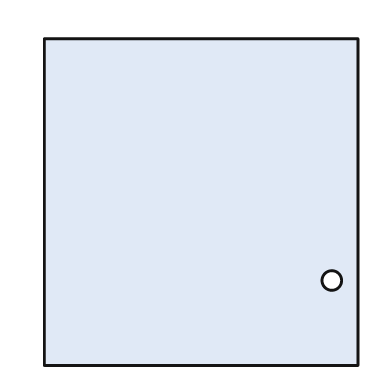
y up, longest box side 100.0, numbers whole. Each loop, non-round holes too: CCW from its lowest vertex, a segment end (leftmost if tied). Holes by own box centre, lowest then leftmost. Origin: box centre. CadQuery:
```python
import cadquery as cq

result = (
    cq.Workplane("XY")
    .moveTo(-48.0, -50.0)
    .lineTo(48.0, -50.0)
    .lineTo(48.0, 50.0)
    .lineTo(-48.0, 50.0)
    .close()
    .moveTo(40.0, -24.0)
    .circle(3.0)
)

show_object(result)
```